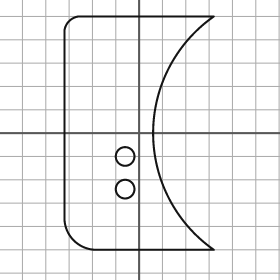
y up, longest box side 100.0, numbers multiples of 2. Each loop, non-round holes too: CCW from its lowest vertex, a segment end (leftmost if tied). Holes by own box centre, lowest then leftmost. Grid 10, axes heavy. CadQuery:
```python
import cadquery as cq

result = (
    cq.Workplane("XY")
    .moveTo(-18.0, -50.0)
    .lineTo(32.0, -50.0)
    .threePointArc((6.0, 0.0), (32.0, 50.0))
    .lineTo(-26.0, 50.0)
    .threePointArc((-30.0, 48.0), (-32.0, 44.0))
    .lineTo(-32.0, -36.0)
    .threePointArc((-28.0, -46.0), (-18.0, -50.0))
    .close()
    .moveTo(-6.0, -24.0)
    .circle(4.0)
    .moveTo(-6.0, -10.0)
    .circle(4.0)
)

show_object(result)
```